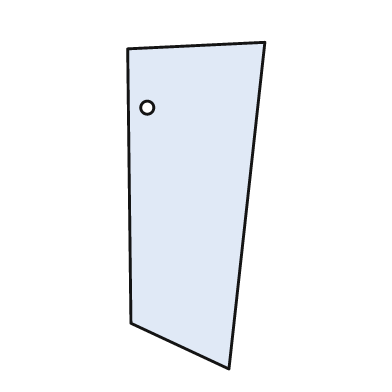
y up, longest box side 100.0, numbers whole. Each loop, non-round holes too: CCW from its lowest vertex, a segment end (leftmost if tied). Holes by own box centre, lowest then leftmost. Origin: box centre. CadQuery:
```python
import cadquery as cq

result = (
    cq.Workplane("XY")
    .moveTo(10.0, -50.0)
    .lineTo(21.0, 50.0)
    .lineTo(-21.0, 48.0)
    .lineTo(-20.0, -36.0)
    .close()
    .moveTo(-15.0, 30.0)
    .circle(2.0)
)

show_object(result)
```